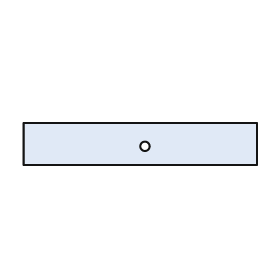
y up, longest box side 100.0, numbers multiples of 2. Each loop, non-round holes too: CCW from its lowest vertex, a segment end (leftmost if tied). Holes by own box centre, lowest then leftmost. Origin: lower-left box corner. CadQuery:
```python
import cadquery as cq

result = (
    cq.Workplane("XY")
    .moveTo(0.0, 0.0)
    .lineTo(100.0, 0.0)
    .lineTo(100.0, 18.0)
    .lineTo(0.0, 18.0)
    .close()
    .moveTo(52.0, 8.0)
    .circle(2.0)
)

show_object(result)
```